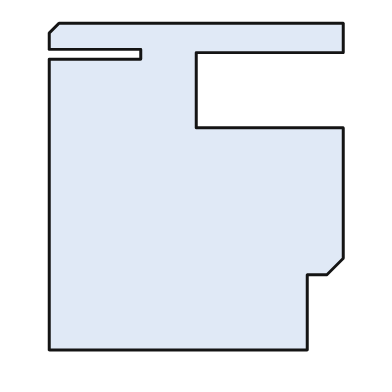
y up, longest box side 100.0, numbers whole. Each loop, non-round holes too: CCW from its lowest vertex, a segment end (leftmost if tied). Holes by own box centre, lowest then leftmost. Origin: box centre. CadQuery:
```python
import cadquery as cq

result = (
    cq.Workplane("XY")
    .moveTo(-45.0, -50.0)
    .lineTo(34.0, -50.0)
    .lineTo(34.0, -27.0)
    .lineTo(40.0, -27.0)
    .lineTo(45.0, -22.0)
    .lineTo(45.0, 18.0)
    .lineTo(0.0, 18.0)
    .lineTo(0.0, 41.0)
    .lineTo(45.0, 41.0)
    .lineTo(45.0, 50.0)
    .lineTo(-42.0, 50.0)
    .lineTo(-45.0, 47.0)
    .lineTo(-45.0, 42.0)
    .lineTo(-17.0, 42.0)
    .lineTo(-17.0, 39.0)
    .lineTo(-45.0, 39.0)
    .close()
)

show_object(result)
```